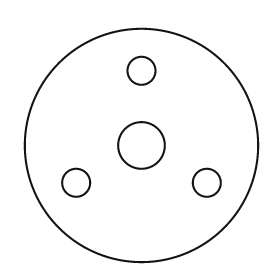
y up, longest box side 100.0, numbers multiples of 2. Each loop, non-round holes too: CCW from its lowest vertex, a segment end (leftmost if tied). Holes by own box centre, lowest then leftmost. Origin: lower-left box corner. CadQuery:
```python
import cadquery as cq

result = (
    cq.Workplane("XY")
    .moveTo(50.0, 50.0)
    .circle(50.0)
    .moveTo(22.0, 34.0)
    .circle(6.0)
    .moveTo(78.0, 34.0)
    .circle(6.0)
    .moveTo(50.0, 50.0)
    .circle(10.0)
    .moveTo(50.0, 82.0)
    .circle(6.0)
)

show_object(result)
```